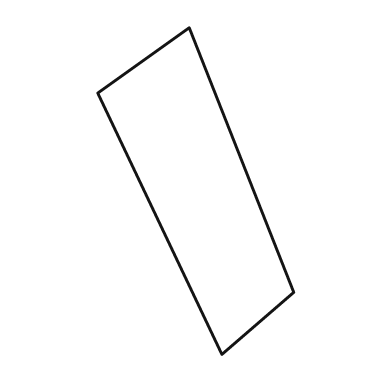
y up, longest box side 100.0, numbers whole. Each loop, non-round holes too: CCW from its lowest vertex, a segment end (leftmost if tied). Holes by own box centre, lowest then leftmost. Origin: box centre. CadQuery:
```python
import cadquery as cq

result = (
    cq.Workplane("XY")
    .moveTo(8.0, -50.0)
    .lineTo(30.0, -31.0)
    .lineTo(-2.0, 50.0)
    .lineTo(-30.0, 30.0)
    .close()
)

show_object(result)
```